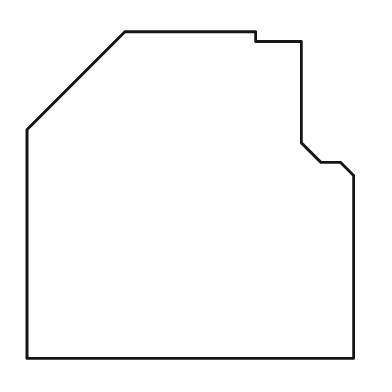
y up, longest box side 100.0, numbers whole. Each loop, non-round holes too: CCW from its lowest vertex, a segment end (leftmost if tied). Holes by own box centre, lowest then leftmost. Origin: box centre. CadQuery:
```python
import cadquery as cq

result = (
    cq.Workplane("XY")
    .moveTo(-50.0, -50.0)
    .lineTo(50.0, -50.0)
    .lineTo(50.0, 6.0)
    .lineTo(46.0, 10.0)
    .lineTo(40.0, 10.0)
    .lineTo(34.0, 16.0)
    .lineTo(34.0, 47.0)
    .lineTo(20.0, 47.0)
    .lineTo(20.0, 50.0)
    .lineTo(-20.0, 50.0)
    .lineTo(-50.0, 20.0)
    .close()
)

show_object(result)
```